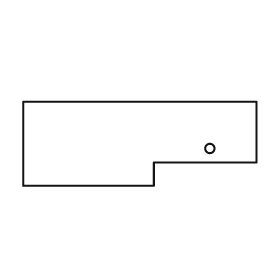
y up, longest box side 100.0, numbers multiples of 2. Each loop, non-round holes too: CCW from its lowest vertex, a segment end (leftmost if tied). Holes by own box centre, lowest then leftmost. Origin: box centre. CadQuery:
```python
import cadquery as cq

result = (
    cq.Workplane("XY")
    .moveTo(-50.0, -18.0)
    .lineTo(6.0, -18.0)
    .lineTo(6.0, -8.0)
    .lineTo(50.0, -8.0)
    .lineTo(50.0, 18.0)
    .lineTo(-50.0, 18.0)
    .close()
    .moveTo(30.0, -2.0)
    .circle(2.0)
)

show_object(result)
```